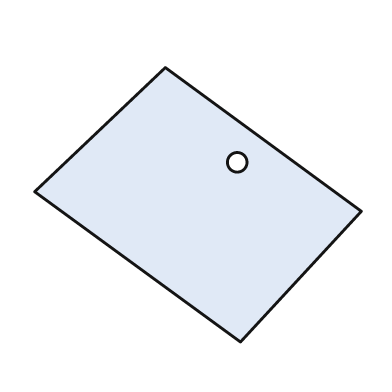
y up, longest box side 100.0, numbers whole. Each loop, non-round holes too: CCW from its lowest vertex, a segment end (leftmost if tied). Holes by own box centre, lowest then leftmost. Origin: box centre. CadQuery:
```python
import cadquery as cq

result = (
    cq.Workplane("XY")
    .moveTo(13.0, -42.0)
    .lineTo(50.0, -2.0)
    .lineTo(-10.0, 42.0)
    .lineTo(-50.0, 4.0)
    .close()
    .moveTo(12.0, 13.0)
    .circle(3.0)
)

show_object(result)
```